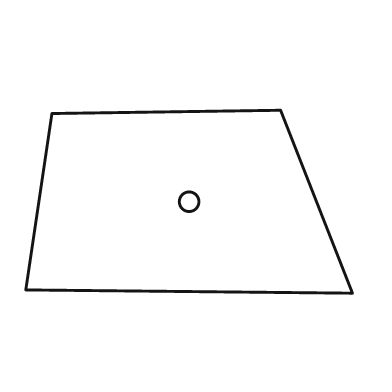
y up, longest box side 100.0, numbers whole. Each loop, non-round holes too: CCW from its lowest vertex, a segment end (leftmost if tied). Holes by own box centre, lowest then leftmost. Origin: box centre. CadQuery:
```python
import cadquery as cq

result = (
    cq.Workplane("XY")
    .moveTo(50.0, -28.0)
    .lineTo(28.0, 28.0)
    .lineTo(-42.0, 27.0)
    .lineTo(-50.0, -27.0)
    .close()
    .moveTo(0.0, 0.0)
    .circle(3.0)
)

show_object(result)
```